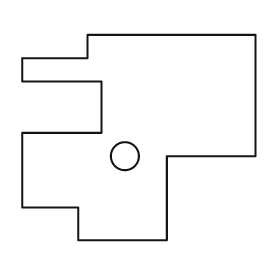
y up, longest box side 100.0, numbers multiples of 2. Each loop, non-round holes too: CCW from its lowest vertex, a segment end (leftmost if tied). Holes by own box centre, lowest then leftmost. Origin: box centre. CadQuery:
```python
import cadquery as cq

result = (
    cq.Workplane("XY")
    .moveTo(-26.0, -44.0)
    .lineTo(12.0, -44.0)
    .lineTo(12.0, -8.0)
    .lineTo(50.0, -8.0)
    .lineTo(50.0, 44.0)
    .lineTo(-22.0, 44.0)
    .lineTo(-22.0, 34.0)
    .lineTo(-50.0, 34.0)
    .lineTo(-50.0, 24.0)
    .lineTo(-16.0, 24.0)
    .lineTo(-16.0, 2.0)
    .lineTo(-50.0, 2.0)
    .lineTo(-50.0, -30.0)
    .lineTo(-26.0, -30.0)
    .close()
    .moveTo(-6.0, -8.0)
    .circle(6.0)
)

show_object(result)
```